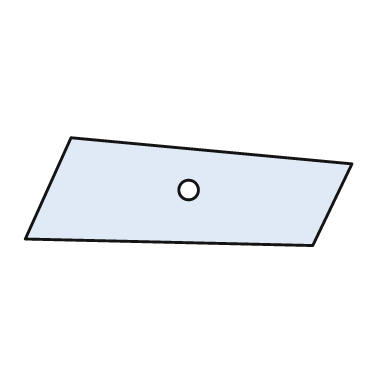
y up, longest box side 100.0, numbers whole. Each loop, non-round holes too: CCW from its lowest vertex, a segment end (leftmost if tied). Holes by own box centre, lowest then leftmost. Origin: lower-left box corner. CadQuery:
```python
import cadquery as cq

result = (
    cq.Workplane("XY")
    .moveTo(88.0, 0.0)
    .lineTo(100.0, 25.0)
    .lineTo(14.0, 33.0)
    .lineTo(0.0, 2.0)
    .close()
    .moveTo(50.0, 17.0)
    .circle(3.0)
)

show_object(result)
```